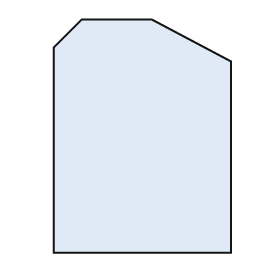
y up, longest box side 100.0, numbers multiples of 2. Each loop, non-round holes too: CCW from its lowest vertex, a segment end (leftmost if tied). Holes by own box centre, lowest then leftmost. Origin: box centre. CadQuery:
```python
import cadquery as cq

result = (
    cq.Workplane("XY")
    .moveTo(-38.0, -50.0)
    .lineTo(38.0, -50.0)
    .lineTo(38.0, 32.0)
    .lineTo(4.0, 50.0)
    .lineTo(-26.0, 50.0)
    .lineTo(-38.0, 38.0)
    .close()
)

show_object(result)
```